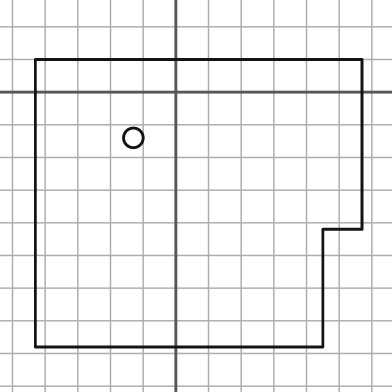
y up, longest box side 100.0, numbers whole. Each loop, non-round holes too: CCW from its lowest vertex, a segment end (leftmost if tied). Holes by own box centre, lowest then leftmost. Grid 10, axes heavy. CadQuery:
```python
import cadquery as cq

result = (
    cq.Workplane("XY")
    .moveTo(-43.0, -78.0)
    .lineTo(45.0, -78.0)
    .lineTo(45.0, -42.0)
    .lineTo(57.0, -42.0)
    .lineTo(57.0, 10.0)
    .lineTo(-43.0, 10.0)
    .close()
    .moveTo(-13.0, -14.0)
    .circle(3.0)
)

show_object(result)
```